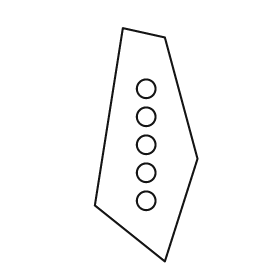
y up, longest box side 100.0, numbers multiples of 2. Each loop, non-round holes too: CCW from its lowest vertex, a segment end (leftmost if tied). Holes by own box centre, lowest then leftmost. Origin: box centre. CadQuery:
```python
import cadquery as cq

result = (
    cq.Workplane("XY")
    .moveTo(8.0, -50.0)
    .lineTo(22.0, -6.0)
    .lineTo(8.0, 46.0)
    .lineTo(-10.0, 50.0)
    .lineTo(-22.0, -26.0)
    .close()
    .moveTo(0.0, -24.0)
    .circle(4.0)
    .moveTo(0.0, -12.0)
    .circle(4.0)
    .moveTo(0.0, 0.0)
    .circle(4.0)
    .moveTo(0.0, 12.0)
    .circle(4.0)
    .moveTo(0.0, 24.0)
    .circle(4.0)
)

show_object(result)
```